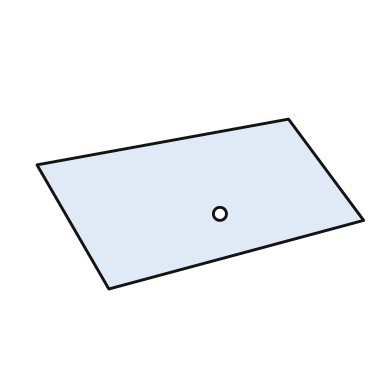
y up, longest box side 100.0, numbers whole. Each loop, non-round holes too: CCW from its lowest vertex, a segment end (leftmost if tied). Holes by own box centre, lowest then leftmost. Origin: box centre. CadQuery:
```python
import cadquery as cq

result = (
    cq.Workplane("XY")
    .moveTo(-28.0, -26.0)
    .lineTo(50.0, -5.0)
    .lineTo(27.0, 26.0)
    .lineTo(-50.0, 12.0)
    .close()
    .moveTo(6.0, -3.0)
    .circle(2.0)
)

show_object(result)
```